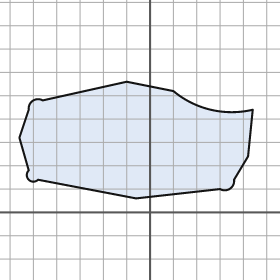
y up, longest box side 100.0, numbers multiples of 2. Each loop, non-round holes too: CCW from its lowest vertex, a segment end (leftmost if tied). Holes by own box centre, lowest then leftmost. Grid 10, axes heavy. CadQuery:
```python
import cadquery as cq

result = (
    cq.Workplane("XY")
    .moveTo(-6.0, 6.0)
    .lineTo(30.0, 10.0)
    .threePointArc((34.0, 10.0), (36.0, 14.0))
    .lineTo(42.0, 24.0)
    .lineTo(44.0, 44.0)
    .threePointArc((26.0, 44.0), (10.0, 52.0))
    .lineTo(-10.0, 56.0)
    .lineTo(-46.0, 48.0)
    .threePointArc((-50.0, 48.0), (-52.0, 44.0))
    .lineTo(-56.0, 32.0)
    .lineTo(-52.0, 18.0)
    .threePointArc((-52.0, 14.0), (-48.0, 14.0))
    .close()
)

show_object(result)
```